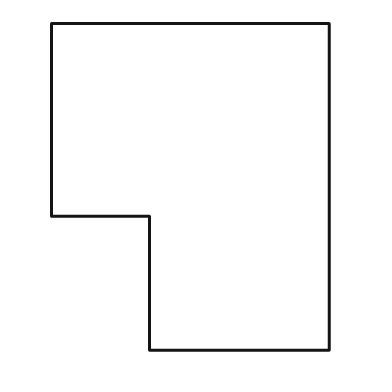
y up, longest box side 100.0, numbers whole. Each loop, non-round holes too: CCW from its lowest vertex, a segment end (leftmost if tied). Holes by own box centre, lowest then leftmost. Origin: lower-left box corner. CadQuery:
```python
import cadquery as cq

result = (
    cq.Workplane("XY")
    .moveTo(30.0, 0.0)
    .lineTo(85.0, 0.0)
    .lineTo(85.0, 100.0)
    .lineTo(0.0, 100.0)
    .lineTo(0.0, 41.0)
    .lineTo(30.0, 41.0)
    .close()
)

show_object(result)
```